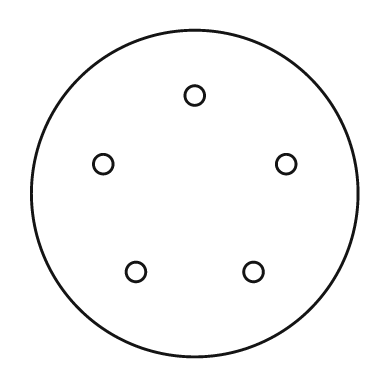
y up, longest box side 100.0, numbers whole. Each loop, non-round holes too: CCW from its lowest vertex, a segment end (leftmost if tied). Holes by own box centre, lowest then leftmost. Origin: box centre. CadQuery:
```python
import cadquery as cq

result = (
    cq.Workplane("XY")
    .moveTo(0.0, 0.0)
    .circle(50.0)
    .moveTo(-18.0, -24.0)
    .circle(3.0)
    .moveTo(18.0, -24.0)
    .circle(3.0)
    .moveTo(-28.0, 9.0)
    .circle(3.0)
    .moveTo(28.0, 9.0)
    .circle(3.0)
    .moveTo(0.0, 30.0)
    .circle(3.0)
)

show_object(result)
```